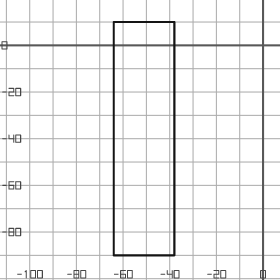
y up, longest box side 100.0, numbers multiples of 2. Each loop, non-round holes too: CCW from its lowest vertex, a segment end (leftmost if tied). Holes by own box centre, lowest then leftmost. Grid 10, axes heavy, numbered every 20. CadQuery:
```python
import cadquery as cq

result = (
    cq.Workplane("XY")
    .moveTo(-64.0, -90.0)
    .lineTo(-38.0, -90.0)
    .lineTo(-38.0, 10.0)
    .lineTo(-64.0, 10.0)
    .close()
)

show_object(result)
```